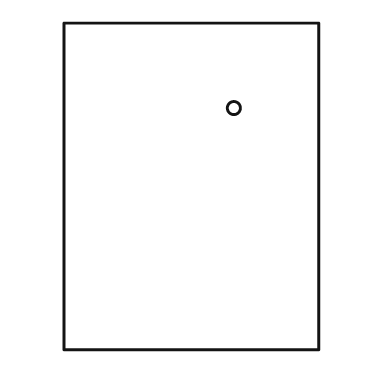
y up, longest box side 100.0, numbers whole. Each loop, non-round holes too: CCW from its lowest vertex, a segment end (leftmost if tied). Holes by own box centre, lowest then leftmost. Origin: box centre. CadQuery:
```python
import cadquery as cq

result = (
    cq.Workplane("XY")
    .moveTo(-39.0, -50.0)
    .lineTo(39.0, -50.0)
    .lineTo(39.0, 50.0)
    .lineTo(-39.0, 50.0)
    .close()
    .moveTo(13.0, 24.0)
    .circle(2.0)
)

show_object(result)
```